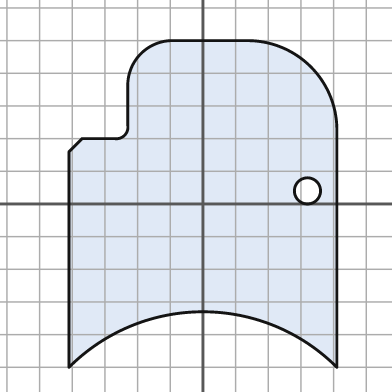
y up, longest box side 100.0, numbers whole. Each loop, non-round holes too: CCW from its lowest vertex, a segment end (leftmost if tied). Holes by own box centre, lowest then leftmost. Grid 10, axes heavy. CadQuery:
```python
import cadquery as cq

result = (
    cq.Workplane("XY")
    .moveTo(-41.0, -50.0)
    .threePointArc((0.0, -33.0), (41.0, -50.0))
    .lineTo(41.0, 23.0)
    .threePointArc((33.0, 42.0), (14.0, 50.0))
    .lineTo(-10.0, 50.0)
    .threePointArc((-19.0, 46.0), (-23.0, 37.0))
    .lineTo(-23.0, 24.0)
    .threePointArc((-24.0, 21.0), (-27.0, 20.0))
    .lineTo(-37.0, 20.0)
    .lineTo(-41.0, 16.0)
    .close()
    .moveTo(32.0, 4.0)
    .circle(4.0)
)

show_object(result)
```